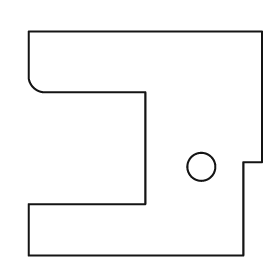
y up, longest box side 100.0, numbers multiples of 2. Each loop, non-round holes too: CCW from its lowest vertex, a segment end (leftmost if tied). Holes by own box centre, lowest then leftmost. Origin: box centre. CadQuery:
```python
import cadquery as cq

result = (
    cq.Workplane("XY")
    .moveTo(-50.0, -48.0)
    .lineTo(42.0, -48.0)
    .lineTo(42.0, -8.0)
    .lineTo(50.0, -8.0)
    .lineTo(50.0, 48.0)
    .lineTo(-50.0, 48.0)
    .lineTo(-50.0, 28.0)
    .threePointArc((-48.0, 24.0), (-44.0, 22.0))
    .lineTo(0.0, 22.0)
    .lineTo(0.0, -26.0)
    .lineTo(-50.0, -26.0)
    .close()
    .moveTo(24.0, -10.0)
    .circle(6.0)
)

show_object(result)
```